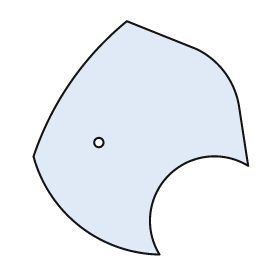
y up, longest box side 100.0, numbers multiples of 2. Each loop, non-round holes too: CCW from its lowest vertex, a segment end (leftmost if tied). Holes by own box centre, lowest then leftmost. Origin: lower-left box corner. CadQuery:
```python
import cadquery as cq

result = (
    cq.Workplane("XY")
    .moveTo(54.0, 0.0)
    .threePointArc((58.0, 34.0), (92.0, 38.0))
    .lineTo(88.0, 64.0)
    .threePointArc((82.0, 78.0), (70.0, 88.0))
    .lineTo(40.0, 100.0)
    .threePointArc((16.0, 74.0), (0.0, 42.0))
    .threePointArc((20.0, 12.0), (54.0, 0.0))
    .close()
    .moveTo(28.0, 48.0)
    .circle(2.0)
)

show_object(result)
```